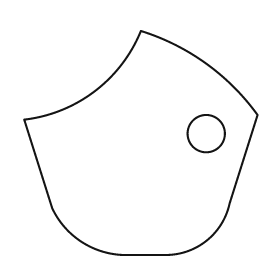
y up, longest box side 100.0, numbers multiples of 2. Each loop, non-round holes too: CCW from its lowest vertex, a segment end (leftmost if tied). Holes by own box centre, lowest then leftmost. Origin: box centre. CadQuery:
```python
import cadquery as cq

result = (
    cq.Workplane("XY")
    .moveTo(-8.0, -48.0)
    .lineTo(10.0, -48.0)
    .threePointArc((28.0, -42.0), (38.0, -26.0))
    .lineTo(50.0, 12.0)
    .threePointArc((28.0, 34.0), (0.0, 48.0))
    .threePointArc((-20.0, 22.0), (-50.0, 10.0))
    .lineTo(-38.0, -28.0)
    .threePointArc((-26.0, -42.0), (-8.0, -48.0))
    .close()
    .moveTo(28.0, 4.0)
    .circle(8.0)
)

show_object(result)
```